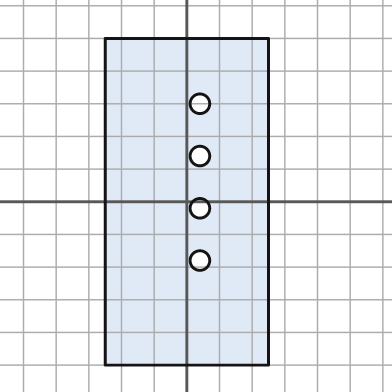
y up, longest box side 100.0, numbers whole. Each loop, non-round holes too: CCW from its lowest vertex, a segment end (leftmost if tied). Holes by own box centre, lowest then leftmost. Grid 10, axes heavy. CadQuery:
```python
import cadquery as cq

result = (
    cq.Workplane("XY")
    .moveTo(-25.0, -50.0)
    .lineTo(25.0, -50.0)
    .lineTo(25.0, 50.0)
    .lineTo(-25.0, 50.0)
    .close()
    .moveTo(4.0, -18.0)
    .circle(3.0)
    .moveTo(4.0, -2.0)
    .circle(3.0)
    .moveTo(4.0, 14.0)
    .circle(3.0)
    .moveTo(4.0, 30.0)
    .circle(3.0)
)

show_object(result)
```